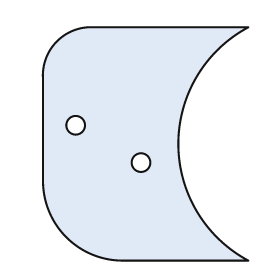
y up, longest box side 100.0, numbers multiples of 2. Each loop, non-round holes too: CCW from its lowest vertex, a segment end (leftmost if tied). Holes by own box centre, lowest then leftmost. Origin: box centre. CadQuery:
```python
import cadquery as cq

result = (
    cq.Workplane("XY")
    .moveTo(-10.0, -50.0)
    .lineTo(44.0, -50.0)
    .threePointArc((14.0, 0.0), (44.0, 50.0))
    .lineTo(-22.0, 50.0)
    .threePointArc((-38.0, 44.0), (-44.0, 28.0))
    .lineTo(-44.0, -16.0)
    .threePointArc((-34.0, -40.0), (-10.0, -50.0))
    .close()
    .moveTo(-2.0, -8.0)
    .circle(4.0)
    .moveTo(-30.0, 8.0)
    .circle(4.0)
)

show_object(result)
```